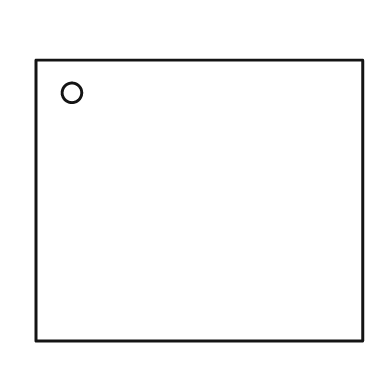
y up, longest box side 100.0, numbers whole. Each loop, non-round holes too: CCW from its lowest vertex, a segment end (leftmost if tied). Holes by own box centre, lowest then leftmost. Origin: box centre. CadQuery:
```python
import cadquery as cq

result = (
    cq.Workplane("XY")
    .moveTo(-50.0, -43.0)
    .lineTo(50.0, -43.0)
    .lineTo(50.0, 43.0)
    .lineTo(-50.0, 43.0)
    .close()
    .moveTo(-39.0, 33.0)
    .circle(3.0)
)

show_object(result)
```